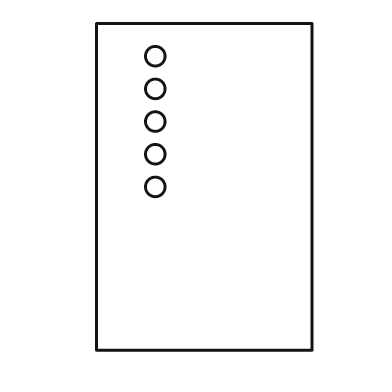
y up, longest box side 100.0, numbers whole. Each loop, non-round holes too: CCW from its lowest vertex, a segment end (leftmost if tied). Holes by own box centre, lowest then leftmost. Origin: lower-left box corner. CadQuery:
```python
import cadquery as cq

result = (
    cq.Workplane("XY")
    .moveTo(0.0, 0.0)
    .lineTo(66.0, 0.0)
    .lineTo(66.0, 100.0)
    .lineTo(0.0, 100.0)
    .close()
    .moveTo(18.0, 50.0)
    .circle(3.0)
    .moveTo(18.0, 60.0)
    .circle(3.0)
    .moveTo(18.0, 70.0)
    .circle(3.0)
    .moveTo(18.0, 80.0)
    .circle(3.0)
    .moveTo(18.0, 90.0)
    .circle(3.0)
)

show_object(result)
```